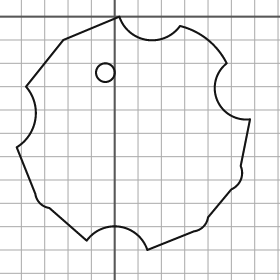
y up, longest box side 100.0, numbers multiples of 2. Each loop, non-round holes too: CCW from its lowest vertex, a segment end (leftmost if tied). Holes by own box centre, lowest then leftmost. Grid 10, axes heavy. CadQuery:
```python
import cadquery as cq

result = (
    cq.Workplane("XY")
    .moveTo(14.0, -100.0)
    .lineTo(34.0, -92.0)
    .threePointArc((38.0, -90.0), (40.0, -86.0))
    .lineTo(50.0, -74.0)
    .threePointArc((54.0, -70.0), (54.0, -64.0))
    .lineTo(58.0, -44.0)
    .threePointArc((44.0, -36.0), (48.0, -20.0))
    .threePointArc((40.0, -10.0), (28.0, -4.0))
    .threePointArc((14.0, -10.0), (2.0, 0.0))
    .lineTo(-22.0, -10.0)
    .lineTo(-38.0, -30.0)
    .threePointArc((-34.0, -44.0), (-42.0, -56.0))
    .lineTo(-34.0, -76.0)
    .threePointArc((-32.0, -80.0), (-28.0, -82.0))
    .lineTo(-12.0, -96.0)
    .threePointArc((2.0, -90.0), (14.0, -100.0))
    .close()
    .moveTo(-4.0, -24.0)
    .circle(4.0)
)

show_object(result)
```